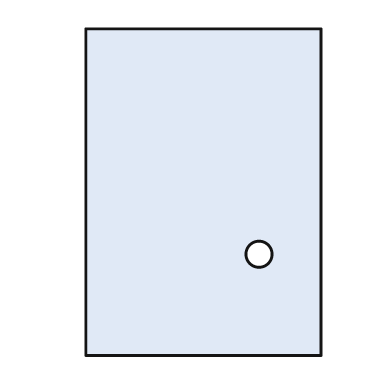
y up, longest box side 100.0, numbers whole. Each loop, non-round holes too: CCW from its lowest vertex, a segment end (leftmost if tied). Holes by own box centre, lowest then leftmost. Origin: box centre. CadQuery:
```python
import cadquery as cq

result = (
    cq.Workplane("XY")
    .moveTo(-36.0, -50.0)
    .lineTo(36.0, -50.0)
    .lineTo(36.0, 50.0)
    .lineTo(-36.0, 50.0)
    .close()
    .moveTo(17.0, -19.0)
    .circle(4.0)
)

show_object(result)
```